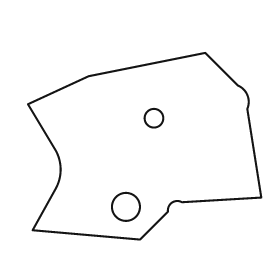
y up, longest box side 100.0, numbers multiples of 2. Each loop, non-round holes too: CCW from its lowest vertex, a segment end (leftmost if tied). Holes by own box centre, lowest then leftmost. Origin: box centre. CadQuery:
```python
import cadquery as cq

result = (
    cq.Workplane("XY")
    .moveTo(-2.0, -40.0)
    .lineTo(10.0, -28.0)
    .threePointArc((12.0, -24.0), (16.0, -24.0))
    .lineTo(50.0, -22.0)
    .lineTo(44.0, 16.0)
    .threePointArc((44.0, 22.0), (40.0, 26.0))
    .lineTo(26.0, 40.0)
    .lineTo(-24.0, 30.0)
    .lineTo(-50.0, 18.0)
    .lineTo(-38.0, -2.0)
    .threePointArc((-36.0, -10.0), (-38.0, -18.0))
    .lineTo(-48.0, -36.0)
    .close()
    .moveTo(-8.0, -26.0)
    .circle(6.0)
    .moveTo(4.0, 12.0)
    .circle(4.0)
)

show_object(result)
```